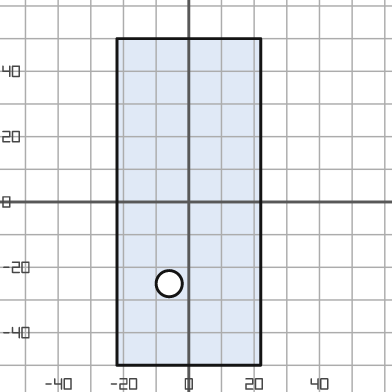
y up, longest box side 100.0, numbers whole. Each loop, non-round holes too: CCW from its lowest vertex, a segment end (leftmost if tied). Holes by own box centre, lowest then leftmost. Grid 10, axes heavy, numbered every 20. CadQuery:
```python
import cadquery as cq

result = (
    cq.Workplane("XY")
    .moveTo(-22.0, -50.0)
    .lineTo(22.0, -50.0)
    .lineTo(22.0, 50.0)
    .lineTo(-22.0, 50.0)
    .close()
    .moveTo(-6.0, -25.0)
    .circle(4.0)
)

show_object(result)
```